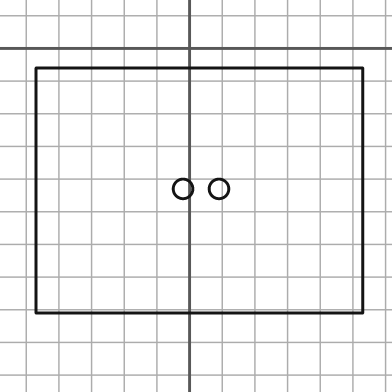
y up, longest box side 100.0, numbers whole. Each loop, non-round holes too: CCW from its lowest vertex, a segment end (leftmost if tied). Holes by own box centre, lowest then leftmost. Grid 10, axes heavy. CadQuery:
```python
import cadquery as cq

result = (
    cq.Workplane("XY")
    .moveTo(-47.0, -81.0)
    .lineTo(53.0, -81.0)
    .lineTo(53.0, -6.0)
    .lineTo(-47.0, -6.0)
    .close()
    .moveTo(-2.0, -43.0)
    .circle(3.0)
    .moveTo(9.0, -43.0)
    .circle(3.0)
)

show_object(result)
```